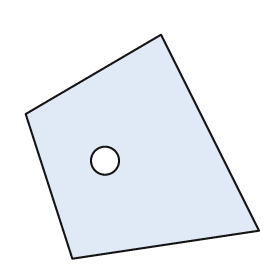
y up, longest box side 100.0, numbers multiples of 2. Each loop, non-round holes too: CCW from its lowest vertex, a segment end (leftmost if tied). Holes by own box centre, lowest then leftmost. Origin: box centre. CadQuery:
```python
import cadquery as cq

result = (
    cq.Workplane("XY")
    .moveTo(-30.0, -48.0)
    .lineTo(50.0, -36.0)
    .lineTo(8.0, 48.0)
    .lineTo(-50.0, 14.0)
    .close()
    .moveTo(-16.0, -6.0)
    .circle(6.0)
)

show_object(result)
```